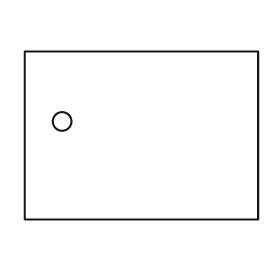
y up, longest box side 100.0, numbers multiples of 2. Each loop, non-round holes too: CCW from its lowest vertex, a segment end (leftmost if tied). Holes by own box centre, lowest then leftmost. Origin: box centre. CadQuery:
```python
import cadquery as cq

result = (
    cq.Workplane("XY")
    .moveTo(-50.0, -36.0)
    .lineTo(50.0, -36.0)
    .lineTo(50.0, 36.0)
    .lineTo(-50.0, 36.0)
    .close()
    .moveTo(-34.0, 6.0)
    .circle(4.0)
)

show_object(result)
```